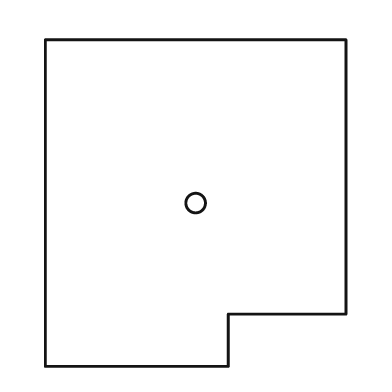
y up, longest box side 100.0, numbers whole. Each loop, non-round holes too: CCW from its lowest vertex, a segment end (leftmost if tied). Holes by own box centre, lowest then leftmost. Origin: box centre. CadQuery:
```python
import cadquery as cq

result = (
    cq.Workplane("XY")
    .moveTo(-46.0, -50.0)
    .lineTo(10.0, -50.0)
    .lineTo(10.0, -34.0)
    .lineTo(46.0, -34.0)
    .lineTo(46.0, 50.0)
    .lineTo(-46.0, 50.0)
    .close()
    .moveTo(0.0, 0.0)
    .circle(3.0)
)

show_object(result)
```